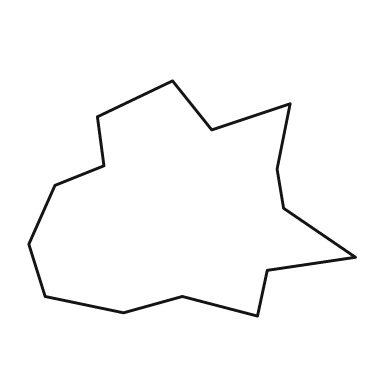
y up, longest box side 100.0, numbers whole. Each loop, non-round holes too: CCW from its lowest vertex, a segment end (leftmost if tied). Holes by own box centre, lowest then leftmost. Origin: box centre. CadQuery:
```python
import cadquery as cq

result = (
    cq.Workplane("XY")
    .moveTo(20.0, -36.0)
    .lineTo(23.0, -22.0)
    .lineTo(50.0, -18.0)
    .lineTo(28.0, -3.0)
    .lineTo(26.0, 9.0)
    .lineTo(30.0, 29.0)
    .lineTo(6.0, 21.0)
    .lineTo(-6.0, 36.0)
    .lineTo(-29.0, 25.0)
    .lineTo(-27.0, 10.0)
    .lineTo(-42.0, 4.0)
    .lineTo(-50.0, -14.0)
    .lineTo(-45.0, -30.0)
    .lineTo(-21.0, -35.0)
    .lineTo(-3.0, -30.0)
    .close()
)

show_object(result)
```